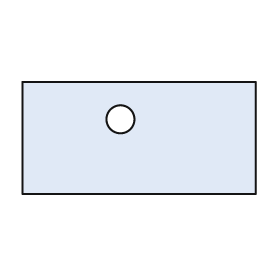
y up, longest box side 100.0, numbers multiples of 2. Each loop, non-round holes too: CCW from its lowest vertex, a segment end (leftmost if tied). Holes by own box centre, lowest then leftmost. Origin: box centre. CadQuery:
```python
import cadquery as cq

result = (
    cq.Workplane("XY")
    .moveTo(-50.0, -24.0)
    .lineTo(50.0, -24.0)
    .lineTo(50.0, 24.0)
    .lineTo(-50.0, 24.0)
    .close()
    .moveTo(-8.0, 8.0)
    .circle(6.0)
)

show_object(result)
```